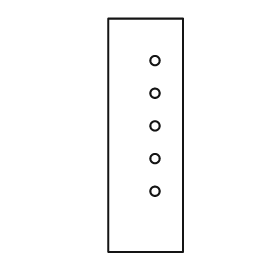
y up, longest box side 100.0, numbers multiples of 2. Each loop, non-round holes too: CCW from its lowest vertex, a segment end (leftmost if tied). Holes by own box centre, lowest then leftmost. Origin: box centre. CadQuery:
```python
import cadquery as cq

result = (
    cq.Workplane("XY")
    .moveTo(-16.0, -50.0)
    .lineTo(16.0, -50.0)
    .lineTo(16.0, 50.0)
    .lineTo(-16.0, 50.0)
    .close()
    .moveTo(4.0, -24.0)
    .circle(2.0)
    .moveTo(4.0, -10.0)
    .circle(2.0)
    .moveTo(4.0, 4.0)
    .circle(2.0)
    .moveTo(4.0, 18.0)
    .circle(2.0)
    .moveTo(4.0, 32.0)
    .circle(2.0)
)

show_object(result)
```